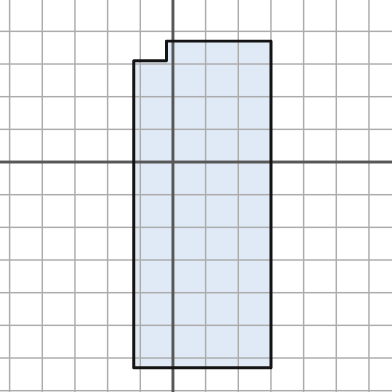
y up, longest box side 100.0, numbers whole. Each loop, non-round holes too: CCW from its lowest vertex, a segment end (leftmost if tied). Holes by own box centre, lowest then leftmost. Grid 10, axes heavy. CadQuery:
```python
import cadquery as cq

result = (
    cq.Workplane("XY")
    .moveTo(-12.0, -63.0)
    .lineTo(30.0, -63.0)
    .lineTo(30.0, 37.0)
    .lineTo(-2.0, 37.0)
    .lineTo(-2.0, 31.0)
    .lineTo(-12.0, 31.0)
    .close()
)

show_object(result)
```